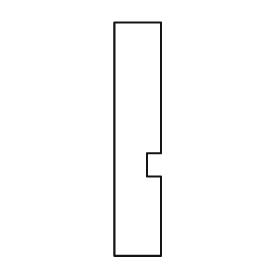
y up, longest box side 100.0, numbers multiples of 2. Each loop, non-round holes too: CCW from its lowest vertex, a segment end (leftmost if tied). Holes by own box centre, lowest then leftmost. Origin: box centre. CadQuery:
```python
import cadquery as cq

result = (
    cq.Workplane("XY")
    .moveTo(-10.0, -50.0)
    .lineTo(10.0, -50.0)
    .lineTo(10.0, -16.0)
    .lineTo(4.0, -16.0)
    .lineTo(4.0, -6.0)
    .lineTo(10.0, -6.0)
    .lineTo(10.0, 50.0)
    .lineTo(-10.0, 50.0)
    .close()
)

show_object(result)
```